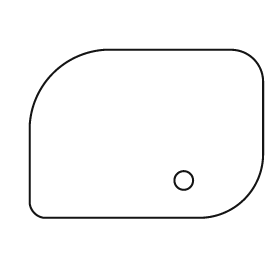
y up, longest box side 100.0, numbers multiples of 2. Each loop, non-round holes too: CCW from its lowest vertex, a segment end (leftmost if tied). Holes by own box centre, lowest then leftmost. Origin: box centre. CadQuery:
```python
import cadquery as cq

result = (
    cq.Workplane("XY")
    .moveTo(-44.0, -36.0)
    .lineTo(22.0, -36.0)
    .threePointArc((42.0, -28.0), (50.0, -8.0))
    .lineTo(50.0, 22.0)
    .threePointArc((46.0, 32.0), (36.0, 36.0))
    .lineTo(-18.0, 36.0)
    .threePointArc((-40.0, 26.0), (-50.0, 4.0))
    .lineTo(-50.0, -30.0)
    .threePointArc((-48.0, -34.0), (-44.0, -36.0))
    .close()
    .moveTo(16.0, -20.0)
    .circle(4.0)
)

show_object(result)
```